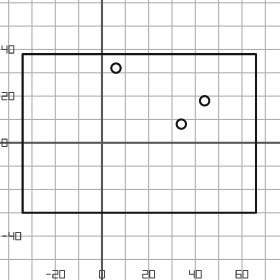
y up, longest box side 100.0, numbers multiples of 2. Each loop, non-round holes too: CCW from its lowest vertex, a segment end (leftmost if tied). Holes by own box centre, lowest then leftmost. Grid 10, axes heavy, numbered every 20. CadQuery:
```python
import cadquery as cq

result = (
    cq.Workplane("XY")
    .moveTo(-34.0, -30.0)
    .lineTo(66.0, -30.0)
    .lineTo(66.0, 38.0)
    .lineTo(-34.0, 38.0)
    .close()
    .moveTo(34.0, 8.0)
    .circle(2.0)
    .moveTo(44.0, 18.0)
    .circle(2.0)
    .moveTo(6.0, 32.0)
    .circle(2.0)
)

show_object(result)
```